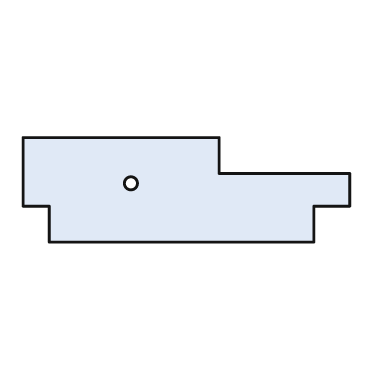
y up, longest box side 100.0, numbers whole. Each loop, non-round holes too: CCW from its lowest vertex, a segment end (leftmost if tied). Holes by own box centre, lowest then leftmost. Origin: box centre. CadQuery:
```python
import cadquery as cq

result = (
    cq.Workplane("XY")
    .moveTo(-42.0, -16.0)
    .lineTo(39.0, -16.0)
    .lineTo(39.0, -5.0)
    .lineTo(50.0, -5.0)
    .lineTo(50.0, 5.0)
    .lineTo(10.0, 5.0)
    .lineTo(10.0, 16.0)
    .lineTo(-50.0, 16.0)
    .lineTo(-50.0, -5.0)
    .lineTo(-42.0, -5.0)
    .close()
    .moveTo(-17.0, 2.0)
    .circle(2.0)
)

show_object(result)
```